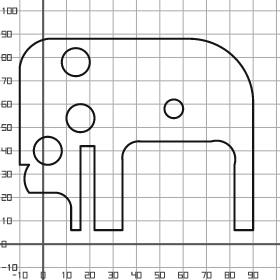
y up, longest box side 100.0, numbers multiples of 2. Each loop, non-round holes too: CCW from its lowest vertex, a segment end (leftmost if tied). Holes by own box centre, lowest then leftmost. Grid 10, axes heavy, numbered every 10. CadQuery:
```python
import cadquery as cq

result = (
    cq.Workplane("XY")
    .moveTo(12.0, 6.0)
    .lineTo(16.0, 6.0)
    .lineTo(16.0, 42.0)
    .lineTo(22.0, 42.0)
    .lineTo(22.0, 6.0)
    .lineTo(34.0, 6.0)
    .lineTo(34.0, 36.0)
    .threePointArc((36.0, 42.0), (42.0, 44.0))
    .lineTo(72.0, 44.0)
    .threePointArc((80.0, 42.0), (82.0, 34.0))
    .lineTo(82.0, 6.0)
    .lineTo(90.0, 6.0)
    .lineTo(90.0, 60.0)
    .threePointArc((82.0, 80.0), (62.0, 88.0))
    .lineTo(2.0, 88.0)
    .threePointArc((-6.0, 84.0), (-10.0, 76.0))
    .lineTo(-10.0, 34.0)
    .lineTo(-6.0, 34.0)
    .threePointArc((-8.0, 28.0), (-6.0, 22.0))
    .lineTo(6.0, 22.0)
    .threePointArc((10.0, 20.0), (12.0, 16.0))
    .close()
    .moveTo(2.0, 40.0)
    .circle(6.0)
    .moveTo(16.0, 54.0)
    .circle(6.0)
    .moveTo(56.0, 58.0)
    .circle(4.0)
    .moveTo(14.0, 78.0)
    .circle(6.0)
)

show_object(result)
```